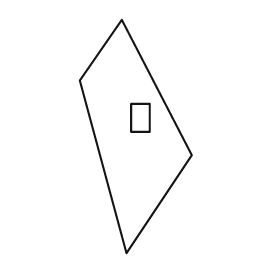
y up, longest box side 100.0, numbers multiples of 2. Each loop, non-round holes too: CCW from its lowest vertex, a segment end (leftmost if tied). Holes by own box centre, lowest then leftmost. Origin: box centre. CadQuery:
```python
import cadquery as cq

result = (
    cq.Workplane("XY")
    .moveTo(-4.0, -50.0)
    .lineTo(24.0, -8.0)
    .lineTo(-6.0, 50.0)
    .lineTo(-24.0, 24.0)
    .close()
    .moveTo(-2.0, 2.0)
    .lineTo(6.0, 2.0)
    .lineTo(6.0, 14.0)
    .lineTo(-2.0, 14.0)
    .close()
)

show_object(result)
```